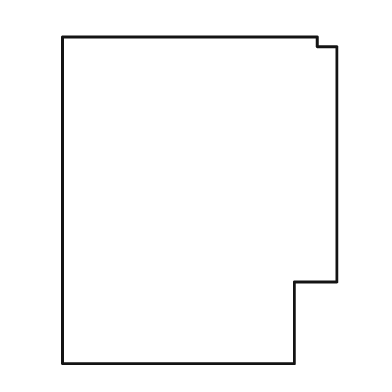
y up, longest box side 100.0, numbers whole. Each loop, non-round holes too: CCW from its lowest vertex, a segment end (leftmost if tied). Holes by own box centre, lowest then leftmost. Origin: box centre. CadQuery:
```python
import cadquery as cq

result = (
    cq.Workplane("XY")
    .moveTo(-42.0, -50.0)
    .lineTo(29.0, -50.0)
    .lineTo(29.0, -25.0)
    .lineTo(42.0, -25.0)
    .lineTo(42.0, 47.0)
    .lineTo(36.0, 47.0)
    .lineTo(36.0, 50.0)
    .lineTo(-42.0, 50.0)
    .close()
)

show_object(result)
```